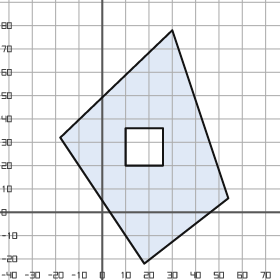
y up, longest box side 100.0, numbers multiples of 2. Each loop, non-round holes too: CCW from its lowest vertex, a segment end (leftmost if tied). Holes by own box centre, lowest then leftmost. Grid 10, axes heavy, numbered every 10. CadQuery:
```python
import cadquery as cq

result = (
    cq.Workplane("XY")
    .moveTo(18.0, -22.0)
    .lineTo(54.0, 6.0)
    .lineTo(30.0, 78.0)
    .lineTo(-18.0, 32.0)
    .close()
    .moveTo(10.0, 20.0)
    .lineTo(26.0, 20.0)
    .lineTo(26.0, 36.0)
    .lineTo(10.0, 36.0)
    .close()
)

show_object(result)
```